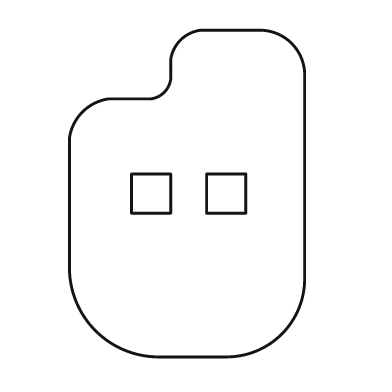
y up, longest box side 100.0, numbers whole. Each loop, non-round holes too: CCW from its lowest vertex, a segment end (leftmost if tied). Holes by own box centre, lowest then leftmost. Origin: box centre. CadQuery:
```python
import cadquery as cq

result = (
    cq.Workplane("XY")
    .moveTo(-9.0, -50.0)
    .lineTo(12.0, -50.0)
    .threePointArc((29.0, -43.0), (36.0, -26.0))
    .lineTo(36.0, 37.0)
    .threePointArc((32.0, 46.0), (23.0, 50.0))
    .lineTo(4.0, 50.0)
    .threePointArc((-2.0, 47.0), (-5.0, 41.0))
    .lineTo(-5.0, 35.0)
    .threePointArc((-7.0, 31.0), (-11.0, 29.0))
    .lineTo(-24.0, 29.0)
    .threePointArc((-32.0, 25.0), (-36.0, 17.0))
    .lineTo(-36.0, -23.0)
    .threePointArc((-28.0, -42.0), (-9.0, -50.0))
    .close()
    .moveTo(-17.0, -6.0)
    .lineTo(-5.0, -6.0)
    .lineTo(-5.0, 6.0)
    .lineTo(-17.0, 6.0)
    .close()
    .moveTo(6.0, -6.0)
    .lineTo(18.0, -6.0)
    .lineTo(18.0, 6.0)
    .lineTo(6.0, 6.0)
    .close()
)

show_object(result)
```